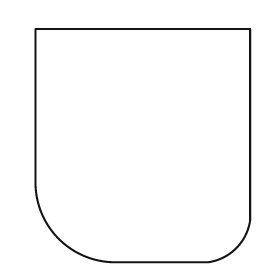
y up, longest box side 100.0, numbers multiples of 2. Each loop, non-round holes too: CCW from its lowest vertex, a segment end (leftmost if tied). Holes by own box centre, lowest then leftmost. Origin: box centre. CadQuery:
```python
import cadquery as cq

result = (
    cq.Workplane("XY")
    .moveTo(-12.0, -50.0)
    .lineTo(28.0, -50.0)
    .threePointArc((40.0, -44.0), (46.0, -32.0))
    .lineTo(46.0, 50.0)
    .lineTo(-46.0, 50.0)
    .lineTo(-46.0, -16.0)
    .threePointArc((-36.0, -40.0), (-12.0, -50.0))
    .close()
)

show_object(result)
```